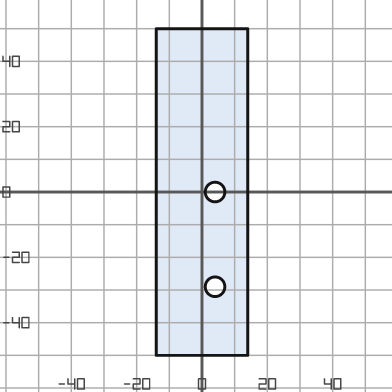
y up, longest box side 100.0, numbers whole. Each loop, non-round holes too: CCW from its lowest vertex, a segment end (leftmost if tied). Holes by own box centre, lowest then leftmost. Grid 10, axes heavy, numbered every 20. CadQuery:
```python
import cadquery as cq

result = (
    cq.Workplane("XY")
    .moveTo(-14.0, -50.0)
    .lineTo(14.0, -50.0)
    .lineTo(14.0, 50.0)
    .lineTo(-14.0, 50.0)
    .close()
    .moveTo(4.0, -29.0)
    .circle(3.0)
    .moveTo(4.0, 0.0)
    .circle(3.0)
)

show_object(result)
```